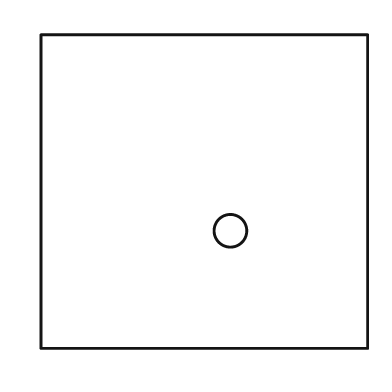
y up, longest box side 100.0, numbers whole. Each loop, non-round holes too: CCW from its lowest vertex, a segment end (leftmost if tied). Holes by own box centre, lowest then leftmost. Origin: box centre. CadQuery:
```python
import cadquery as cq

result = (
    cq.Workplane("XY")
    .moveTo(-50.0, -48.0)
    .lineTo(50.0, -48.0)
    .lineTo(50.0, 48.0)
    .lineTo(-50.0, 48.0)
    .close()
    .moveTo(8.0, -12.0)
    .circle(5.0)
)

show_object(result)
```